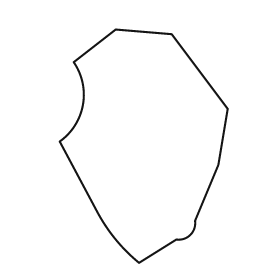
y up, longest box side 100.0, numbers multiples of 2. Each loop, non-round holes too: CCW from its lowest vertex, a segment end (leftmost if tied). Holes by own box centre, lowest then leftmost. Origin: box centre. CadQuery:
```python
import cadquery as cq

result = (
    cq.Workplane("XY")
    .moveTo(-2.0, -50.0)
    .lineTo(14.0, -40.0)
    .threePointArc((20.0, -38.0), (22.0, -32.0))
    .lineTo(32.0, -8.0)
    .lineTo(36.0, 16.0)
    .lineTo(12.0, 48.0)
    .lineTo(-12.0, 50.0)
    .lineTo(-30.0, 36.0)
    .threePointArc((-26.0, 18.0), (-36.0, 2.0))
    .lineTo(-20.0, -28.0)
    .threePointArc((-12.0, -40.0), (-2.0, -50.0))
    .close()
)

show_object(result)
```